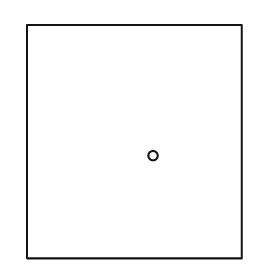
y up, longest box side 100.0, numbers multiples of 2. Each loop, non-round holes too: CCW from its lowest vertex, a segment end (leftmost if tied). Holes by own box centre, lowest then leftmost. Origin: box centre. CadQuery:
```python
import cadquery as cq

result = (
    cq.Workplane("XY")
    .moveTo(-46.0, -50.0)
    .lineTo(46.0, -50.0)
    .lineTo(46.0, 50.0)
    .lineTo(-46.0, 50.0)
    .close()
    .moveTo(8.0, -6.0)
    .circle(2.0)
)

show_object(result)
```